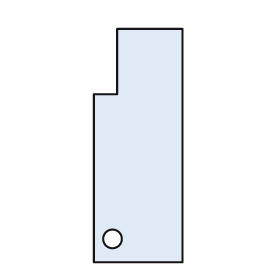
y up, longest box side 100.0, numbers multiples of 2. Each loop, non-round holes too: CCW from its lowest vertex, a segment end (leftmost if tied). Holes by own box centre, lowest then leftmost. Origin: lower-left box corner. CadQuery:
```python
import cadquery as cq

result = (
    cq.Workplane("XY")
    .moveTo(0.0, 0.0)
    .lineTo(38.0, 0.0)
    .lineTo(38.0, 100.0)
    .lineTo(10.0, 100.0)
    .lineTo(10.0, 72.0)
    .lineTo(0.0, 72.0)
    .close()
    .moveTo(8.0, 10.0)
    .circle(4.0)
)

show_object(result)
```